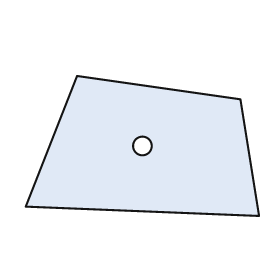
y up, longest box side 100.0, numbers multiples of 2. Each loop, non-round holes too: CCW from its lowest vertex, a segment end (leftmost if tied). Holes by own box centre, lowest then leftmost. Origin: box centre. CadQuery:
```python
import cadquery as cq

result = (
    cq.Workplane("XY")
    .moveTo(50.0, -30.0)
    .lineTo(42.0, 20.0)
    .lineTo(-28.0, 30.0)
    .lineTo(-50.0, -26.0)
    .close()
    .moveTo(0.0, 0.0)
    .circle(4.0)
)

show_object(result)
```